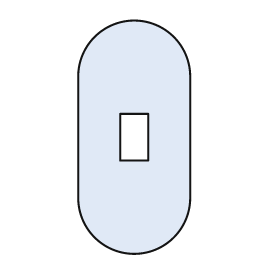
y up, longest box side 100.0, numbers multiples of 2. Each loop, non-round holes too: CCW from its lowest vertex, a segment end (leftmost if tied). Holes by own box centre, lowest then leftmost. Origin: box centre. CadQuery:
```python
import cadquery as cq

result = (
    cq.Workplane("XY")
    .moveTo(-24.0, -26.0)
    .threePointArc((0.0, -50.0), (24.0, -26.0))
    .lineTo(24.0, 26.0)
    .threePointArc((0.0, 50.0), (-24.0, 26.0))
    .close()
    .moveTo(-6.0, -10.0)
    .lineTo(6.0, -10.0)
    .lineTo(6.0, 10.0)
    .lineTo(-6.0, 10.0)
    .close()
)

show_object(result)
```